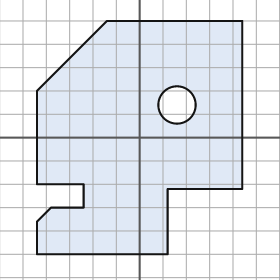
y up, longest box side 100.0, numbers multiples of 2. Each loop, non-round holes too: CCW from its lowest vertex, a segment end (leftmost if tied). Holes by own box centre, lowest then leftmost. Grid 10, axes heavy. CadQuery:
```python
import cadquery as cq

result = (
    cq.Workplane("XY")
    .moveTo(-44.0, -50.0)
    .lineTo(12.0, -50.0)
    .lineTo(12.0, -22.0)
    .lineTo(44.0, -22.0)
    .lineTo(44.0, 50.0)
    .lineTo(-14.0, 50.0)
    .lineTo(-44.0, 20.0)
    .lineTo(-44.0, -20.0)
    .lineTo(-24.0, -20.0)
    .lineTo(-24.0, -30.0)
    .lineTo(-38.0, -30.0)
    .lineTo(-44.0, -36.0)
    .close()
    .moveTo(16.0, 14.0)
    .circle(8.0)
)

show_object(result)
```